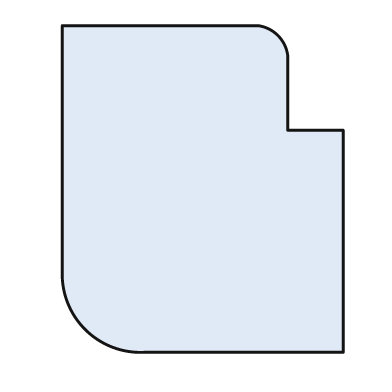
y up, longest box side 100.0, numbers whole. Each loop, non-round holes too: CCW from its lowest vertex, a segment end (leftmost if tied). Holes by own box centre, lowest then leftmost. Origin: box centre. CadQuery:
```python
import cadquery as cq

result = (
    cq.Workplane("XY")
    .moveTo(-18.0, -50.0)
    .lineTo(43.0, -50.0)
    .lineTo(43.0, 18.0)
    .lineTo(26.0, 18.0)
    .lineTo(26.0, 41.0)
    .threePointArc((23.0, 47.0), (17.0, 50.0))
    .lineTo(-43.0, 50.0)
    .lineTo(-43.0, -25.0)
    .threePointArc((-36.0, -43.0), (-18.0, -50.0))
    .close()
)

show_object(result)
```